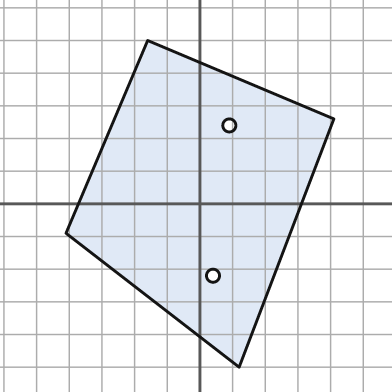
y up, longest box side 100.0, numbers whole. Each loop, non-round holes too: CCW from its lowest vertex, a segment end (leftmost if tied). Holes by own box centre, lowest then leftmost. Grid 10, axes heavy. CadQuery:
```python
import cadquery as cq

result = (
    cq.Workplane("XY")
    .moveTo(12.0, -50.0)
    .lineTo(41.0, 26.0)
    .lineTo(-16.0, 50.0)
    .lineTo(-41.0, -9.0)
    .close()
    .moveTo(4.0, -22.0)
    .circle(2.0)
    .moveTo(9.0, 24.0)
    .circle(2.0)
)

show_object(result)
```